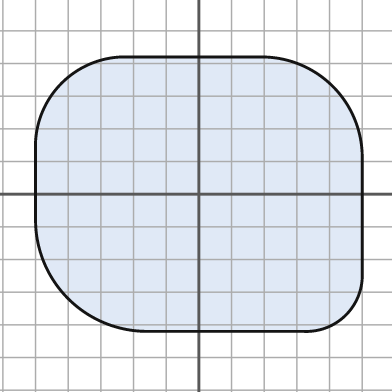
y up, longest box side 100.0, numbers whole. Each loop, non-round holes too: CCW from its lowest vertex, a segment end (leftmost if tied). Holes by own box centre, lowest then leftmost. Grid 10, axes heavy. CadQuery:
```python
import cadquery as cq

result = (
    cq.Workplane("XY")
    .moveTo(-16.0, -42.0)
    .lineTo(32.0, -42.0)
    .threePointArc((45.0, -37.0), (50.0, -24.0))
    .lineTo(50.0, 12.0)
    .threePointArc((41.0, 33.0), (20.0, 42.0))
    .lineTo(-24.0, 42.0)
    .threePointArc((-42.0, 34.0), (-50.0, 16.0))
    .lineTo(-50.0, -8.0)
    .threePointArc((-40.0, -32.0), (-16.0, -42.0))
    .close()
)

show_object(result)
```